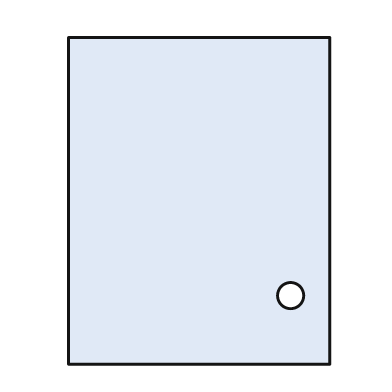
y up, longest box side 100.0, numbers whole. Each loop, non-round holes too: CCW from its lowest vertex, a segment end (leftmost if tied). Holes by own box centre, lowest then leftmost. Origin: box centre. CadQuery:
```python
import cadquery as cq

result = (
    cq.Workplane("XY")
    .moveTo(-40.0, -50.0)
    .lineTo(40.0, -50.0)
    .lineTo(40.0, 50.0)
    .lineTo(-40.0, 50.0)
    .close()
    .moveTo(28.0, -29.0)
    .circle(4.0)
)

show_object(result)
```